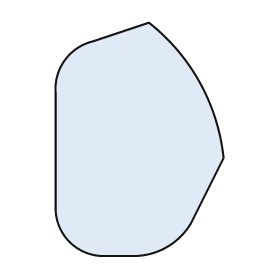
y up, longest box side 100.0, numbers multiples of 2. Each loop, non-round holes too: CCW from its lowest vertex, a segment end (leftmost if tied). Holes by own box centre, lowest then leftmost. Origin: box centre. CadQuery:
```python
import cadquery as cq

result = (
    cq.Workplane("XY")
    .moveTo(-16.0, -50.0)
    .lineTo(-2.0, -50.0)
    .threePointArc((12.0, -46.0), (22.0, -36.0))
    .lineTo(36.0, -8.0)
    .threePointArc((26.0, 24.0), (4.0, 50.0))
    .lineTo(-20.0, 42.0)
    .threePointArc((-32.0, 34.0), (-36.0, 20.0))
    .lineTo(-36.0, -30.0)
    .threePointArc((-30.0, -44.0), (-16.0, -50.0))
    .close()
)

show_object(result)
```